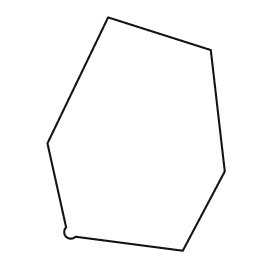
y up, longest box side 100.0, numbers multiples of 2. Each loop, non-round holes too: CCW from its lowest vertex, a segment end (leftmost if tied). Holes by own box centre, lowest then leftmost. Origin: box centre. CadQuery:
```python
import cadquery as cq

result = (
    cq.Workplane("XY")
    .moveTo(20.0, -50.0)
    .lineTo(38.0, -16.0)
    .lineTo(32.0, 36.0)
    .lineTo(-12.0, 50.0)
    .lineTo(-38.0, -4.0)
    .lineTo(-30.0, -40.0)
    .threePointArc((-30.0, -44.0), (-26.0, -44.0))
    .close()
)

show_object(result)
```